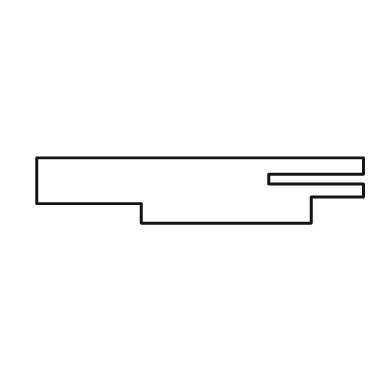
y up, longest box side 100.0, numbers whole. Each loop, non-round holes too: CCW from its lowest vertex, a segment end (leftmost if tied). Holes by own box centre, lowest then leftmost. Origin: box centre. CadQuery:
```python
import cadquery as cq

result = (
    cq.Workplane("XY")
    .moveTo(-18.0, -10.0)
    .lineTo(34.0, -10.0)
    .lineTo(34.0, -2.0)
    .lineTo(50.0, -2.0)
    .lineTo(50.0, 2.0)
    .lineTo(21.0, 2.0)
    .lineTo(21.0, 5.0)
    .lineTo(50.0, 5.0)
    .lineTo(50.0, 10.0)
    .lineTo(-50.0, 10.0)
    .lineTo(-50.0, -4.0)
    .lineTo(-18.0, -4.0)
    .close()
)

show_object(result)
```